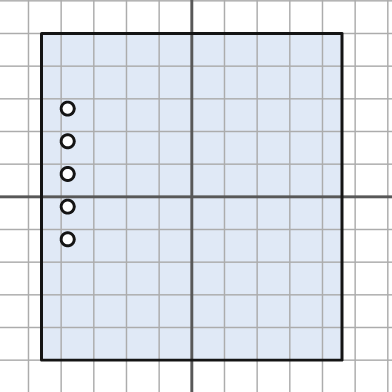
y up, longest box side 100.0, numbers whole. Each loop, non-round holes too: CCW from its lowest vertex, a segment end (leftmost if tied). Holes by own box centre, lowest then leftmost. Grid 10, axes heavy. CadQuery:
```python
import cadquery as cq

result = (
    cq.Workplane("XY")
    .moveTo(-46.0, -50.0)
    .lineTo(46.0, -50.0)
    .lineTo(46.0, 50.0)
    .lineTo(-46.0, 50.0)
    .close()
    .moveTo(-38.0, -13.0)
    .circle(2.0)
    .moveTo(-38.0, -3.0)
    .circle(2.0)
    .moveTo(-38.0, 7.0)
    .circle(2.0)
    .moveTo(-38.0, 17.0)
    .circle(2.0)
    .moveTo(-38.0, 27.0)
    .circle(2.0)
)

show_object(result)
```